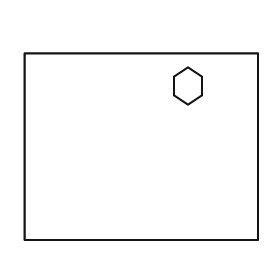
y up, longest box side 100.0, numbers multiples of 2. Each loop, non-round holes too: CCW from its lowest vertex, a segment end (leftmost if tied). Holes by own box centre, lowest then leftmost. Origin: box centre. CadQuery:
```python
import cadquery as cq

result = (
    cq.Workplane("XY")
    .moveTo(-50.0, -40.0)
    .lineTo(50.0, -40.0)
    .lineTo(50.0, 40.0)
    .lineTo(-50.0, 40.0)
    .close()
    .moveTo(20.0, 18.0)
    .lineTo(26.0, 22.0)
    .lineTo(26.0, 30.0)
    .lineTo(20.0, 34.0)
    .lineTo(14.0, 30.0)
    .lineTo(14.0, 22.0)
    .close()
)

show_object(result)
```